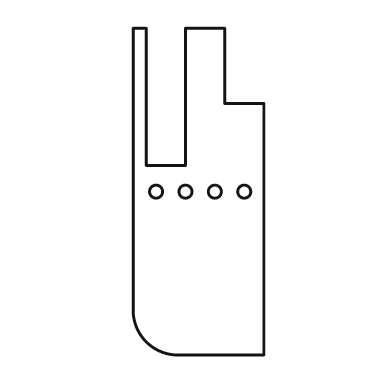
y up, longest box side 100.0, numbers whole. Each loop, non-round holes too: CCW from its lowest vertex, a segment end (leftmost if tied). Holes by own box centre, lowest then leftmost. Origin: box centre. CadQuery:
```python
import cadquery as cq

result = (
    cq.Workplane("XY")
    .moveTo(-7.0, -50.0)
    .lineTo(20.0, -50.0)
    .lineTo(20.0, 27.0)
    .lineTo(8.0, 27.0)
    .lineTo(8.0, 50.0)
    .lineTo(-4.0, 50.0)
    .lineTo(-4.0, 8.0)
    .lineTo(-16.0, 8.0)
    .lineTo(-16.0, 50.0)
    .lineTo(-20.0, 50.0)
    .lineTo(-20.0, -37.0)
    .threePointArc((-16.0, -46.0), (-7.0, -50.0))
    .close()
    .moveTo(-13.0, 0.0)
    .circle(2.0)
    .moveTo(-4.0, 0.0)
    .circle(2.0)
    .moveTo(5.0, 0.0)
    .circle(2.0)
    .moveTo(14.0, 0.0)
    .circle(2.0)
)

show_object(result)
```